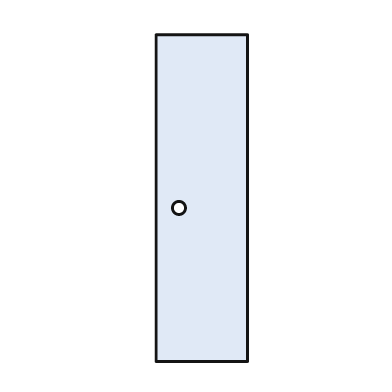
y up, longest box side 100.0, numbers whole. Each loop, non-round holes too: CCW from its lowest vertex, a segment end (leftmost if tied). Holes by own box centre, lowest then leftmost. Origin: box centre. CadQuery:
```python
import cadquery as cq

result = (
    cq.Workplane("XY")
    .moveTo(-14.0, -50.0)
    .lineTo(14.0, -50.0)
    .lineTo(14.0, 50.0)
    .lineTo(-14.0, 50.0)
    .close()
    .moveTo(-7.0, -3.0)
    .circle(2.0)
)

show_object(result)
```